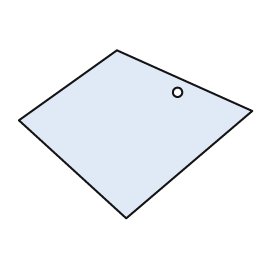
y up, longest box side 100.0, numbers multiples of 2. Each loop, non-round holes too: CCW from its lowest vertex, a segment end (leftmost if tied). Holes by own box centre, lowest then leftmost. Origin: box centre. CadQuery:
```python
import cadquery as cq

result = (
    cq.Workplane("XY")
    .moveTo(-4.0, -36.0)
    .lineTo(50.0, 10.0)
    .lineTo(-8.0, 36.0)
    .lineTo(-50.0, 6.0)
    .close()
    .moveTo(18.0, 18.0)
    .circle(2.0)
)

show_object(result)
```